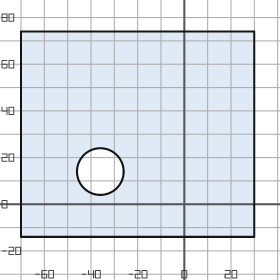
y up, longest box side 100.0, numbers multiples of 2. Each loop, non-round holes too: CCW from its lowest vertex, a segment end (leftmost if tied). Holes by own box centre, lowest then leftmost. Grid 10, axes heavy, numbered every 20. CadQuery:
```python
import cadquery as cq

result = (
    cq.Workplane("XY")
    .moveTo(-70.0, -14.0)
    .lineTo(30.0, -14.0)
    .lineTo(30.0, 74.0)
    .lineTo(-70.0, 74.0)
    .close()
    .moveTo(-36.0, 14.0)
    .circle(10.0)
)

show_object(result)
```